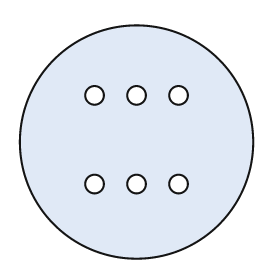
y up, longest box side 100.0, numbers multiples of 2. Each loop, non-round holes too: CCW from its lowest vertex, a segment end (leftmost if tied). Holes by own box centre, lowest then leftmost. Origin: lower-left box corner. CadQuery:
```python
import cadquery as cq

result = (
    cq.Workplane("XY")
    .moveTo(50.0, 50.0)
    .circle(50.0)
    .moveTo(32.0, 32.0)
    .circle(4.0)
    .moveTo(50.0, 32.0)
    .circle(4.0)
    .moveTo(68.0, 32.0)
    .circle(4.0)
    .moveTo(32.0, 70.0)
    .circle(4.0)
    .moveTo(50.0, 70.0)
    .circle(4.0)
    .moveTo(68.0, 70.0)
    .circle(4.0)
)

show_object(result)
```